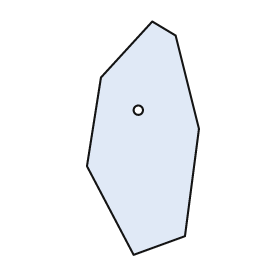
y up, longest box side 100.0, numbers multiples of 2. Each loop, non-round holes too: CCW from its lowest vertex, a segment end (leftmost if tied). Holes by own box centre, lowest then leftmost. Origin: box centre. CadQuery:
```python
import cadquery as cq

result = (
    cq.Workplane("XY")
    .moveTo(-4.0, -50.0)
    .lineTo(18.0, -42.0)
    .lineTo(24.0, 4.0)
    .lineTo(14.0, 44.0)
    .lineTo(4.0, 50.0)
    .lineTo(-18.0, 26.0)
    .lineTo(-24.0, -12.0)
    .close()
    .moveTo(-2.0, 12.0)
    .circle(2.0)
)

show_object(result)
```